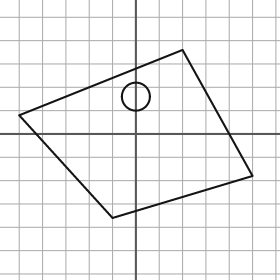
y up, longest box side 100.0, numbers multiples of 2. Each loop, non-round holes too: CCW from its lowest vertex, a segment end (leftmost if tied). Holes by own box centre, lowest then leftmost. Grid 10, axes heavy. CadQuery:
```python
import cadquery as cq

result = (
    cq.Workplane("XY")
    .moveTo(-10.0, -36.0)
    .lineTo(50.0, -18.0)
    .lineTo(20.0, 36.0)
    .lineTo(-50.0, 8.0)
    .close()
    .moveTo(0.0, 16.0)
    .circle(6.0)
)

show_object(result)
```